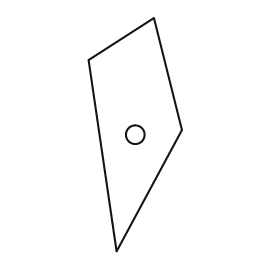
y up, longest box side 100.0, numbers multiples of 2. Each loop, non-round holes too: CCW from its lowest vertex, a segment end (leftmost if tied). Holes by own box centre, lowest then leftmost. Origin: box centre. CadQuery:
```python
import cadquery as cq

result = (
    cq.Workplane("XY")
    .moveTo(-8.0, -50.0)
    .lineTo(20.0, 2.0)
    .lineTo(8.0, 50.0)
    .lineTo(-20.0, 32.0)
    .close()
    .moveTo(0.0, 0.0)
    .circle(4.0)
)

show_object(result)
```